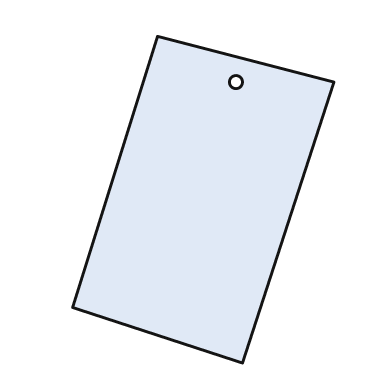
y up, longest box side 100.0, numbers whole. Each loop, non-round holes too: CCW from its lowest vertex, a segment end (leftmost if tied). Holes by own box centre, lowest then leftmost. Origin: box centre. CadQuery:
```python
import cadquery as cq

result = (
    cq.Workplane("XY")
    .moveTo(12.0, -50.0)
    .lineTo(40.0, 36.0)
    .lineTo(-14.0, 50.0)
    .lineTo(-40.0, -33.0)
    .close()
    .moveTo(10.0, 36.0)
    .circle(2.0)
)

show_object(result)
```